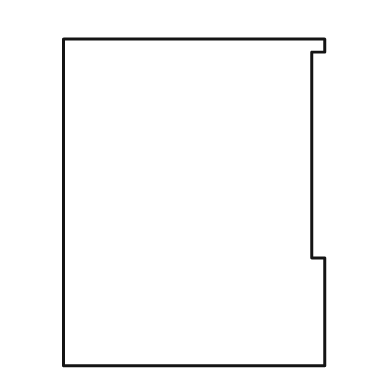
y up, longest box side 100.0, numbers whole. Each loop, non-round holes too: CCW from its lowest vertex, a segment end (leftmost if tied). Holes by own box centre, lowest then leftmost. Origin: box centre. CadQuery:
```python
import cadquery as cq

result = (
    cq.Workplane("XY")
    .moveTo(-40.0, -50.0)
    .lineTo(40.0, -50.0)
    .lineTo(40.0, -17.0)
    .lineTo(36.0, -17.0)
    .lineTo(36.0, 46.0)
    .lineTo(40.0, 46.0)
    .lineTo(40.0, 50.0)
    .lineTo(-40.0, 50.0)
    .close()
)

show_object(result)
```